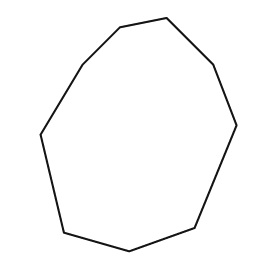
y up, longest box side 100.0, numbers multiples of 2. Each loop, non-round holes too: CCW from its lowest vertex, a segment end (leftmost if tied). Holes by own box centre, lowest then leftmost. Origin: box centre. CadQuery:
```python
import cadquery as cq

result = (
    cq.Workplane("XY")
    .moveTo(-4.0, -50.0)
    .lineTo(24.0, -40.0)
    .lineTo(42.0, 4.0)
    .lineTo(32.0, 30.0)
    .lineTo(12.0, 50.0)
    .lineTo(-8.0, 46.0)
    .lineTo(-24.0, 30.0)
    .lineTo(-42.0, 0.0)
    .lineTo(-32.0, -42.0)
    .close()
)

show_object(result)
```